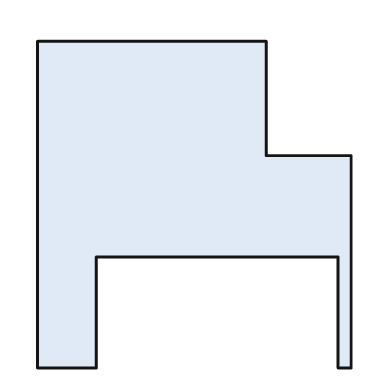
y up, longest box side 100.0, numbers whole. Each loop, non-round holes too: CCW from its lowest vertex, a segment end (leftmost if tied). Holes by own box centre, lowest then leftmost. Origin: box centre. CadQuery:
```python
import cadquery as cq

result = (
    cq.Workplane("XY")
    .moveTo(-48.0, -50.0)
    .lineTo(-30.0, -50.0)
    .lineTo(-30.0, -16.0)
    .lineTo(44.0, -16.0)
    .lineTo(44.0, -50.0)
    .lineTo(48.0, -50.0)
    .lineTo(48.0, 15.0)
    .lineTo(22.0, 15.0)
    .lineTo(22.0, 50.0)
    .lineTo(-48.0, 50.0)
    .close()
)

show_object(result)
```